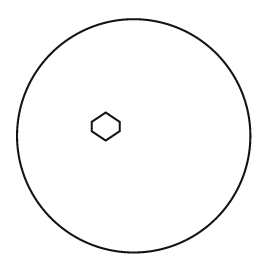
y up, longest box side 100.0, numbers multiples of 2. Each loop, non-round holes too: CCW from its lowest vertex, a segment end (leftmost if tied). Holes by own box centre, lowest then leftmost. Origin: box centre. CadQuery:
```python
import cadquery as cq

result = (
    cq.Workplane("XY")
    .moveTo(0.0, 0.0)
    .circle(50.0)
    .moveTo(-12.0, -2.0)
    .lineTo(-6.0, 2.0)
    .lineTo(-6.0, 6.0)
    .lineTo(-12.0, 10.0)
    .lineTo(-18.0, 6.0)
    .lineTo(-18.0, 2.0)
    .close()
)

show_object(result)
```